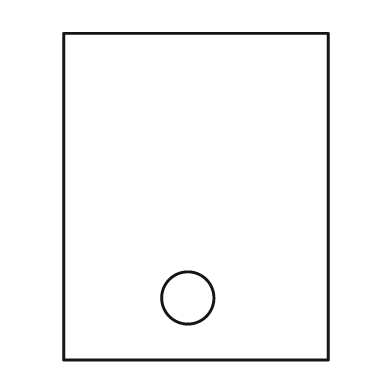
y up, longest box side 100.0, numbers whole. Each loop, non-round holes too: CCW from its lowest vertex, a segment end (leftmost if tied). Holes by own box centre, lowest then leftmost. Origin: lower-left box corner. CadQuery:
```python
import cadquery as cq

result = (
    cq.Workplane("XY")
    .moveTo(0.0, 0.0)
    .lineTo(81.0, 0.0)
    .lineTo(81.0, 100.0)
    .lineTo(0.0, 100.0)
    .close()
    .moveTo(38.0, 19.0)
    .circle(8.0)
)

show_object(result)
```